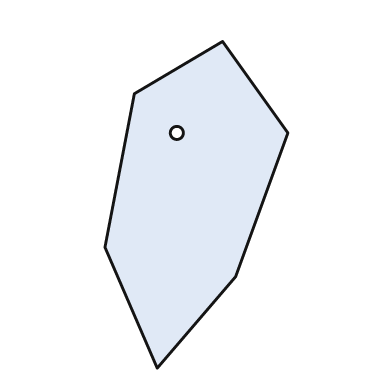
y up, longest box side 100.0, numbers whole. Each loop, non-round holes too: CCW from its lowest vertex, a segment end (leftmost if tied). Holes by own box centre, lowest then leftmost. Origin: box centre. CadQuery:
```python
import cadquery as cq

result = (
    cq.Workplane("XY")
    .moveTo(-12.0, -50.0)
    .lineTo(12.0, -22.0)
    .lineTo(28.0, 22.0)
    .lineTo(8.0, 50.0)
    .lineTo(-19.0, 34.0)
    .lineTo(-28.0, -13.0)
    .close()
    .moveTo(-6.0, 22.0)
    .circle(2.0)
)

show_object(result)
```